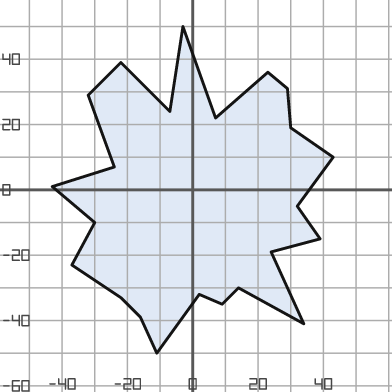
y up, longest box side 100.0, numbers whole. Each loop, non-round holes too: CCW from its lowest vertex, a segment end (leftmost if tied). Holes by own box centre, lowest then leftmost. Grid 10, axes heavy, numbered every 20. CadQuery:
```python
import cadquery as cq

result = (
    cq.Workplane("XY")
    .moveTo(-11.0, -50.0)
    .lineTo(2.0, -32.0)
    .lineTo(9.0, -35.0)
    .lineTo(14.0, -30.0)
    .lineTo(34.0, -41.0)
    .lineTo(24.0, -19.0)
    .lineTo(39.0, -15.0)
    .lineTo(32.0, -5.0)
    .lineTo(43.0, 10.0)
    .lineTo(30.0, 19.0)
    .lineTo(29.0, 31.0)
    .lineTo(23.0, 36.0)
    .lineTo(7.0, 22.0)
    .lineTo(-3.0, 50.0)
    .lineTo(-7.0, 24.0)
    .lineTo(-22.0, 39.0)
    .lineTo(-32.0, 29.0)
    .lineTo(-24.0, 7.0)
    .lineTo(-43.0, 1.0)
    .lineTo(-30.0, -10.0)
    .lineTo(-37.0, -23.0)
    .lineTo(-22.0, -33.0)
    .lineTo(-16.0, -39.0)
    .close()
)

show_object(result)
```